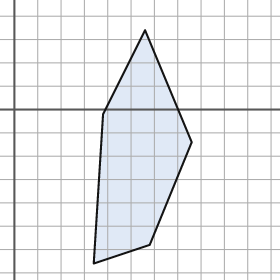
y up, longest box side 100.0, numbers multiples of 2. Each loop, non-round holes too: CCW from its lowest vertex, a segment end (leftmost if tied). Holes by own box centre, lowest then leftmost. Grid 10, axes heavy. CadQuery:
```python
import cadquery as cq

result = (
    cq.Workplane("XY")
    .moveTo(34.0, -66.0)
    .lineTo(58.0, -58.0)
    .lineTo(76.0, -14.0)
    .lineTo(56.0, 34.0)
    .lineTo(38.0, -2.0)
    .close()
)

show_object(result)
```